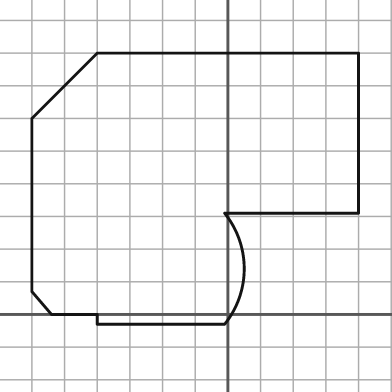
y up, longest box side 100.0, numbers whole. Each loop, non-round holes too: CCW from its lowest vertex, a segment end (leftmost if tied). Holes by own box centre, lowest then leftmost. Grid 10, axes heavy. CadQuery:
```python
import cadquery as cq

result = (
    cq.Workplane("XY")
    .moveTo(-40.0, -3.0)
    .lineTo(-1.0, -3.0)
    .threePointArc((5.0, 14.0), (-1.0, 31.0))
    .lineTo(40.0, 31.0)
    .lineTo(40.0, 80.0)
    .lineTo(-40.0, 80.0)
    .lineTo(-60.0, 60.0)
    .lineTo(-60.0, 7.0)
    .lineTo(-54.0, 0.0)
    .lineTo(-40.0, 0.0)
    .close()
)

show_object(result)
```